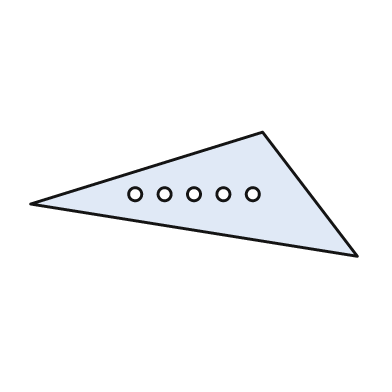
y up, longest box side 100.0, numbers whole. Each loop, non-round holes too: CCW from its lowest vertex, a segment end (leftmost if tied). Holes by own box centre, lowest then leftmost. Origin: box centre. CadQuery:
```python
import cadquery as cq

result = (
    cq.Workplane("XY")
    .moveTo(50.0, -19.0)
    .lineTo(21.0, 19.0)
    .lineTo(-50.0, -3.0)
    .close()
    .moveTo(-18.0, 0.0)
    .circle(2.0)
    .moveTo(-9.0, 0.0)
    .circle(2.0)
    .moveTo(0.0, 0.0)
    .circle(2.0)
    .moveTo(9.0, 0.0)
    .circle(2.0)
    .moveTo(18.0, 0.0)
    .circle(2.0)
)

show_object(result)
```